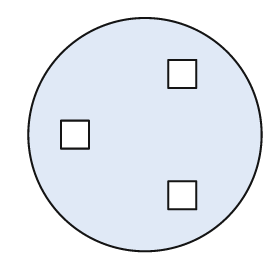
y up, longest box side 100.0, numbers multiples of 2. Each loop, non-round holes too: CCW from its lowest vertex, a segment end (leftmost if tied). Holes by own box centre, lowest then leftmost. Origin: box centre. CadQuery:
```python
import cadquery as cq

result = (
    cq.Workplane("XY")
    .moveTo(0.0, 0.0)
    .circle(50.0)
    .moveTo(10.0, -32.0)
    .lineTo(22.0, -32.0)
    .lineTo(22.0, -20.0)
    .lineTo(10.0, -20.0)
    .close()
    .moveTo(-36.0, -6.0)
    .lineTo(-24.0, -6.0)
    .lineTo(-24.0, 6.0)
    .lineTo(-36.0, 6.0)
    .close()
    .moveTo(10.0, 20.0)
    .lineTo(22.0, 20.0)
    .lineTo(22.0, 32.0)
    .lineTo(10.0, 32.0)
    .close()
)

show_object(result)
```